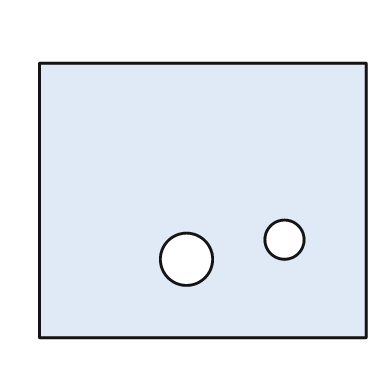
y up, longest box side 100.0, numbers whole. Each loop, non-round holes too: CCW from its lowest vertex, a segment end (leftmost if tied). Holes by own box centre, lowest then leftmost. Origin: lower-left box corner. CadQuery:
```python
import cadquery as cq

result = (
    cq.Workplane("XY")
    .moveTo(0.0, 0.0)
    .lineTo(100.0, 0.0)
    .lineTo(100.0, 84.0)
    .lineTo(0.0, 84.0)
    .close()
    .moveTo(45.0, 24.0)
    .circle(8.0)
    .moveTo(75.0, 30.0)
    .circle(6.0)
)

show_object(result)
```